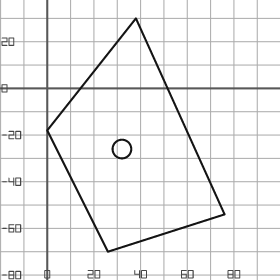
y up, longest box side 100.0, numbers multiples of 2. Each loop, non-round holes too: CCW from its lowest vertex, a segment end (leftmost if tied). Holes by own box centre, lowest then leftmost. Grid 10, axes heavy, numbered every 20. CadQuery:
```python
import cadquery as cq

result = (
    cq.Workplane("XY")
    .moveTo(26.0, -70.0)
    .lineTo(76.0, -54.0)
    .lineTo(38.0, 30.0)
    .lineTo(0.0, -18.0)
    .close()
    .moveTo(32.0, -26.0)
    .circle(4.0)
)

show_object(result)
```